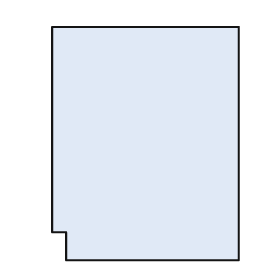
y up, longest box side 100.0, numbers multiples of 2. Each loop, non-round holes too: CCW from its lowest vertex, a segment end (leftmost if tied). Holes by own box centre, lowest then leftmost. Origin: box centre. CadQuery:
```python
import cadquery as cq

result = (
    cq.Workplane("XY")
    .moveTo(-34.0, -50.0)
    .lineTo(40.0, -50.0)
    .lineTo(40.0, 50.0)
    .lineTo(-40.0, 50.0)
    .lineTo(-40.0, -38.0)
    .lineTo(-34.0, -38.0)
    .close()
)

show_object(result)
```